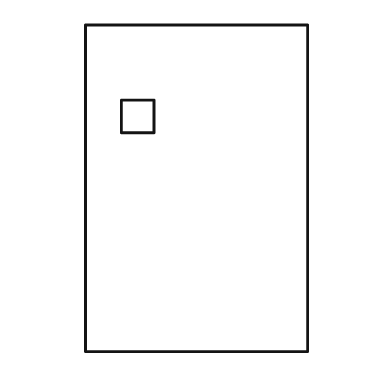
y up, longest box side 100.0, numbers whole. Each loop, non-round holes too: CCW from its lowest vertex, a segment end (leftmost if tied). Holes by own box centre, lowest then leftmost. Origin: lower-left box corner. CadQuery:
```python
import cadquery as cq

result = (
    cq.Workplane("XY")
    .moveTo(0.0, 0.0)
    .lineTo(68.0, 0.0)
    .lineTo(68.0, 100.0)
    .lineTo(0.0, 100.0)
    .close()
    .moveTo(11.0, 67.0)
    .lineTo(21.0, 67.0)
    .lineTo(21.0, 77.0)
    .lineTo(11.0, 77.0)
    .close()
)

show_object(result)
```